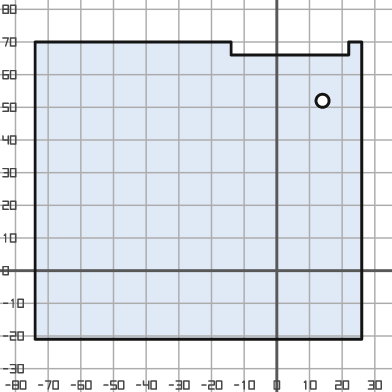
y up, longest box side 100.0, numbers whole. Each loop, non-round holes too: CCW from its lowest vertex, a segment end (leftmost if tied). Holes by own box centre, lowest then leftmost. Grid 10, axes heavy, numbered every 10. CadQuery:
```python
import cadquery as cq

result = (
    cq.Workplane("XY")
    .moveTo(-74.0, -21.0)
    .lineTo(26.0, -21.0)
    .lineTo(26.0, 70.0)
    .lineTo(22.0, 70.0)
    .lineTo(22.0, 66.0)
    .lineTo(-14.0, 66.0)
    .lineTo(-14.0, 70.0)
    .lineTo(-74.0, 70.0)
    .close()
    .moveTo(14.0, 52.0)
    .circle(2.0)
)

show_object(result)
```